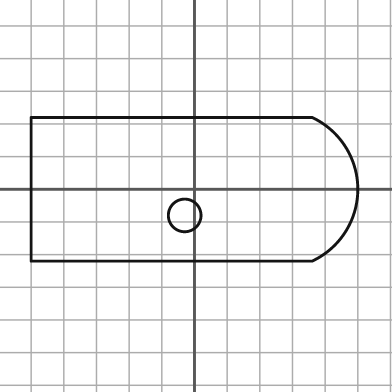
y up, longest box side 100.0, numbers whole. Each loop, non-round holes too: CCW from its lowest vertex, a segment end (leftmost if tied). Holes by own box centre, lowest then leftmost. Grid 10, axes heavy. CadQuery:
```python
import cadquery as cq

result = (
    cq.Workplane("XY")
    .moveTo(-50.0, -22.0)
    .lineTo(36.0, -22.0)
    .threePointArc((50.0, 0.0), (36.0, 22.0))
    .lineTo(-50.0, 22.0)
    .close()
    .moveTo(-3.0, -8.0)
    .circle(5.0)
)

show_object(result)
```